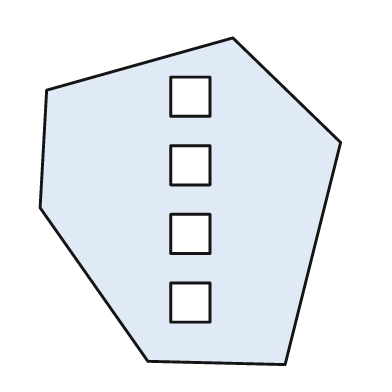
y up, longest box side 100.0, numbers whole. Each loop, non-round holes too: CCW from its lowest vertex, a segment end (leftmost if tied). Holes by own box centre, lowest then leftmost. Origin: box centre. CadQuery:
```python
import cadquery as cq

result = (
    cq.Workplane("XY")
    .moveTo(29.0, -50.0)
    .lineTo(46.0, 18.0)
    .lineTo(13.0, 50.0)
    .lineTo(-44.0, 34.0)
    .lineTo(-46.0, -2.0)
    .lineTo(-13.0, -49.0)
    .close()
    .moveTo(-6.0, -37.0)
    .lineTo(6.0, -37.0)
    .lineTo(6.0, -25.0)
    .lineTo(-6.0, -25.0)
    .close()
    .moveTo(-6.0, -16.0)
    .lineTo(6.0, -16.0)
    .lineTo(6.0, -4.0)
    .lineTo(-6.0, -4.0)
    .close()
    .moveTo(-6.0, 5.0)
    .lineTo(6.0, 5.0)
    .lineTo(6.0, 17.0)
    .lineTo(-6.0, 17.0)
    .close()
    .moveTo(-6.0, 26.0)
    .lineTo(6.0, 26.0)
    .lineTo(6.0, 38.0)
    .lineTo(-6.0, 38.0)
    .close()
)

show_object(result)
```